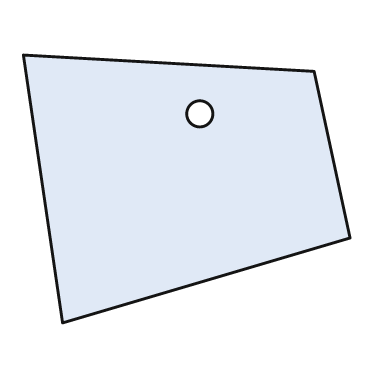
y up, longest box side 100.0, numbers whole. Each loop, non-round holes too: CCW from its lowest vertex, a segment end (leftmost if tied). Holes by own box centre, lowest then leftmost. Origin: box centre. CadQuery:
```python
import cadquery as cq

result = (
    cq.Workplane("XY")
    .moveTo(-38.0, -41.0)
    .lineTo(50.0, -15.0)
    .lineTo(39.0, 36.0)
    .lineTo(-50.0, 41.0)
    .close()
    .moveTo(4.0, 23.0)
    .circle(4.0)
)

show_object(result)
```